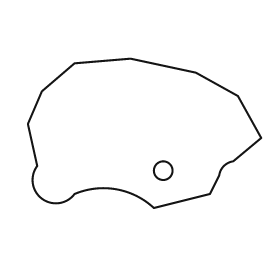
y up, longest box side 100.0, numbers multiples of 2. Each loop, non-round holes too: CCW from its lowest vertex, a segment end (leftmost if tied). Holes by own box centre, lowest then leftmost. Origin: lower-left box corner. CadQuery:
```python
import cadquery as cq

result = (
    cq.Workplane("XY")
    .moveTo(54.0, 0.0)
    .lineTo(78.0, 6.0)
    .lineTo(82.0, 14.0)
    .threePointArc((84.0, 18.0), (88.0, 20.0))
    .lineTo(100.0, 30.0)
    .lineTo(90.0, 48.0)
    .lineTo(72.0, 58.0)
    .lineTo(44.0, 64.0)
    .lineTo(20.0, 62.0)
    .lineTo(6.0, 50.0)
    .lineTo(0.0, 36.0)
    .lineTo(4.0, 18.0)
    .threePointArc((6.0, 4.0), (20.0, 6.0))
    .threePointArc((38.0, 8.0), (54.0, 0.0))
    .close()
    .moveTo(58.0, 16.0)
    .circle(4.0)
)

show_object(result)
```